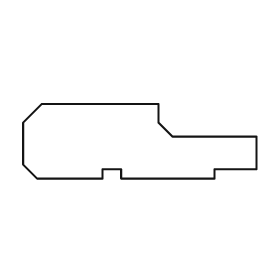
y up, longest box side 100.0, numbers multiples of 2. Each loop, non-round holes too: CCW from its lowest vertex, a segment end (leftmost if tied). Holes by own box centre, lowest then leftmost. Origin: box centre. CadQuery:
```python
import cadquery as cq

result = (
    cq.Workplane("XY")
    .moveTo(-44.0, -16.0)
    .lineTo(-16.0, -16.0)
    .lineTo(-16.0, -12.0)
    .lineTo(-8.0, -12.0)
    .lineTo(-8.0, -16.0)
    .lineTo(32.0, -16.0)
    .lineTo(32.0, -12.0)
    .lineTo(50.0, -12.0)
    .lineTo(50.0, 2.0)
    .lineTo(14.0, 2.0)
    .lineTo(8.0, 8.0)
    .lineTo(8.0, 16.0)
    .lineTo(-42.0, 16.0)
    .lineTo(-50.0, 8.0)
    .lineTo(-50.0, -10.0)
    .close()
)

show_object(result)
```